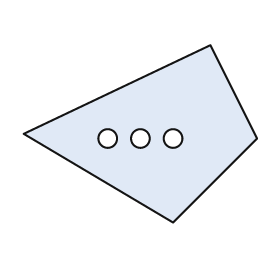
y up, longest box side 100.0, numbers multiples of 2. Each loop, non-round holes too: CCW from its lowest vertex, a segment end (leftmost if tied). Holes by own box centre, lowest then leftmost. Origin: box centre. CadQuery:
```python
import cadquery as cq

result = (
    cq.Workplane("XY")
    .moveTo(14.0, -38.0)
    .lineTo(50.0, -2.0)
    .lineTo(30.0, 38.0)
    .lineTo(-50.0, 0.0)
    .close()
    .moveTo(-14.0, -2.0)
    .circle(4.0)
    .moveTo(0.0, -2.0)
    .circle(4.0)
    .moveTo(14.0, -2.0)
    .circle(4.0)
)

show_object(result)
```